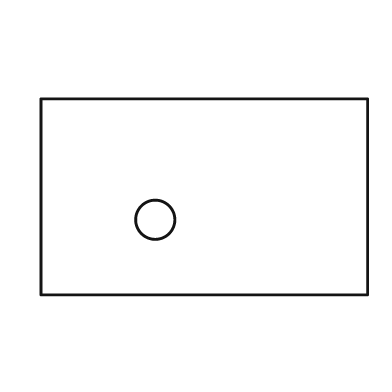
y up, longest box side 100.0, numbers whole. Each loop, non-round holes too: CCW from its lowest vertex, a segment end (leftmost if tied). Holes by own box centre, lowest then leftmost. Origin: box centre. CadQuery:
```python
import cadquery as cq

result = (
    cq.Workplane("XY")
    .moveTo(-50.0, -30.0)
    .lineTo(50.0, -30.0)
    .lineTo(50.0, 30.0)
    .lineTo(-50.0, 30.0)
    .close()
    .moveTo(-15.0, -7.0)
    .circle(6.0)
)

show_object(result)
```